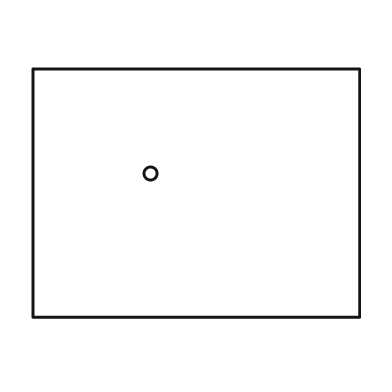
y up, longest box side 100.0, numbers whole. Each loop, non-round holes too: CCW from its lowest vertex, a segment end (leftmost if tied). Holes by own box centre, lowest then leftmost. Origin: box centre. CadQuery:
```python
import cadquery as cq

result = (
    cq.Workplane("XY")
    .moveTo(-50.0, -38.0)
    .lineTo(50.0, -38.0)
    .lineTo(50.0, 38.0)
    .lineTo(-50.0, 38.0)
    .close()
    .moveTo(-14.0, 6.0)
    .circle(2.0)
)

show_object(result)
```